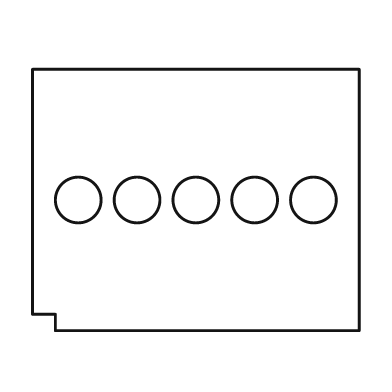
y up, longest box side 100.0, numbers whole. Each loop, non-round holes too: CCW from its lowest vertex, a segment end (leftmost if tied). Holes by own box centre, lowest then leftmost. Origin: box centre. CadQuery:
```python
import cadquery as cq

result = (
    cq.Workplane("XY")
    .moveTo(-43.0, -40.0)
    .lineTo(50.0, -40.0)
    .lineTo(50.0, 40.0)
    .lineTo(-50.0, 40.0)
    .lineTo(-50.0, -35.0)
    .lineTo(-43.0, -35.0)
    .close()
    .moveTo(-36.0, 0.0)
    .circle(7.0)
    .moveTo(-18.0, 0.0)
    .circle(7.0)
    .moveTo(0.0, 0.0)
    .circle(7.0)
    .moveTo(18.0, 0.0)
    .circle(7.0)
    .moveTo(36.0, 0.0)
    .circle(7.0)
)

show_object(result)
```